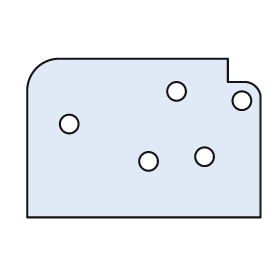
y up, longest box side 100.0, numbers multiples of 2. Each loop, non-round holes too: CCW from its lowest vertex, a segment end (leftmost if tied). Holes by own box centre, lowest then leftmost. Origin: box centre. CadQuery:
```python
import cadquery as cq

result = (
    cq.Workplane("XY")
    .moveTo(-50.0, -34.0)
    .lineTo(50.0, -34.0)
    .lineTo(50.0, 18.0)
    .threePointArc((48.0, 22.0), (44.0, 24.0))
    .lineTo(36.0, 24.0)
    .lineTo(36.0, 34.0)
    .lineTo(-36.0, 34.0)
    .threePointArc((-46.0, 30.0), (-50.0, 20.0))
    .close()
    .moveTo(2.0, -10.0)
    .circle(4.0)
    .moveTo(26.0, -8.0)
    .circle(4.0)
    .moveTo(-32.0, 6.0)
    .circle(4.0)
    .moveTo(42.0, 16.0)
    .circle(4.0)
    .moveTo(14.0, 20.0)
    .circle(4.0)
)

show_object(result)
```